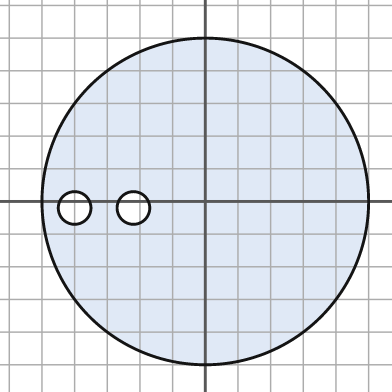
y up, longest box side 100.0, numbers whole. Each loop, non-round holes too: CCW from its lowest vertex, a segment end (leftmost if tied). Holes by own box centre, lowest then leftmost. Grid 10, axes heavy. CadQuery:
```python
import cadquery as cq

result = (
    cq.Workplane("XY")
    .moveTo(0.0, 0.0)
    .circle(50.0)
    .moveTo(-40.0, -2.0)
    .circle(5.0)
    .moveTo(-22.0, -2.0)
    .circle(5.0)
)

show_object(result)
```